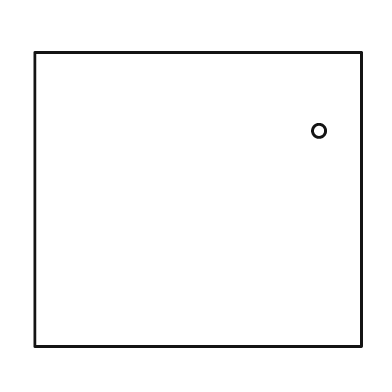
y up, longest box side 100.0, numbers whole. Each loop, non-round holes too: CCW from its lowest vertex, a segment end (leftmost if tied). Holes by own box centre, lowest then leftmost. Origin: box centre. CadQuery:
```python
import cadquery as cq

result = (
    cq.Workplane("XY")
    .moveTo(-50.0, -45.0)
    .lineTo(50.0, -45.0)
    .lineTo(50.0, 45.0)
    .lineTo(-50.0, 45.0)
    .close()
    .moveTo(37.0, 21.0)
    .circle(2.0)
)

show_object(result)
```